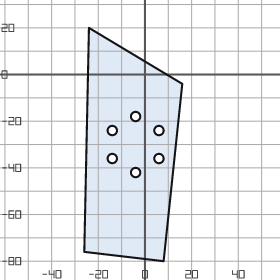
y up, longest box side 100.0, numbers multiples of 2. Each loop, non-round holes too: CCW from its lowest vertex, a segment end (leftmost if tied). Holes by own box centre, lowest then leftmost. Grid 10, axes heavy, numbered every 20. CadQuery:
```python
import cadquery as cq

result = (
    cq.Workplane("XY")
    .moveTo(8.0, -80.0)
    .lineTo(16.0, -4.0)
    .lineTo(-24.0, 20.0)
    .lineTo(-26.0, -76.0)
    .close()
    .moveTo(-4.0, -42.0)
    .circle(2.0)
    .moveTo(-14.0, -36.0)
    .circle(2.0)
    .moveTo(6.0, -36.0)
    .circle(2.0)
    .moveTo(-14.0, -24.0)
    .circle(2.0)
    .moveTo(6.0, -24.0)
    .circle(2.0)
    .moveTo(-4.0, -18.0)
    .circle(2.0)
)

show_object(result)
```